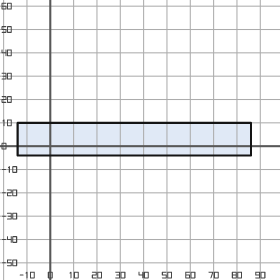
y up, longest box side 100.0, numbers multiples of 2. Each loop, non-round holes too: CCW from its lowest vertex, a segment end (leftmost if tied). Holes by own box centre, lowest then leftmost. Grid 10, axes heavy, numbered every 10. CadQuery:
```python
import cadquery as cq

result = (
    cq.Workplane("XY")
    .moveTo(-14.0, -4.0)
    .lineTo(86.0, -4.0)
    .lineTo(86.0, 10.0)
    .lineTo(-14.0, 10.0)
    .close()
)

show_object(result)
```